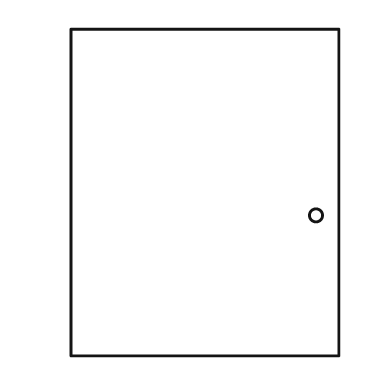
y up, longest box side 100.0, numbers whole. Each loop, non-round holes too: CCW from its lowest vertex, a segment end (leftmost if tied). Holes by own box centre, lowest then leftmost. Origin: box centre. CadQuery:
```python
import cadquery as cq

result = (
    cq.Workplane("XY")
    .moveTo(-41.0, -50.0)
    .lineTo(41.0, -50.0)
    .lineTo(41.0, 50.0)
    .lineTo(-41.0, 50.0)
    .close()
    .moveTo(34.0, -7.0)
    .circle(2.0)
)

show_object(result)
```